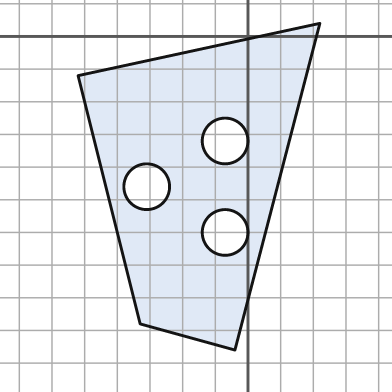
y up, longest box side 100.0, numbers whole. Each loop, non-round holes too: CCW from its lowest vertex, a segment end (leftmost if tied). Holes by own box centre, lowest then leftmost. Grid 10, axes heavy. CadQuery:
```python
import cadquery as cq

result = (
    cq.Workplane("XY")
    .moveTo(-4.0, -96.0)
    .lineTo(22.0, 4.0)
    .lineTo(-52.0, -12.0)
    .lineTo(-33.0, -88.0)
    .close()
    .moveTo(-7.0, -60.0)
    .circle(7.0)
    .moveTo(-31.0, -46.0)
    .circle(7.0)
    .moveTo(-7.0, -32.0)
    .circle(7.0)
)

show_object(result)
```